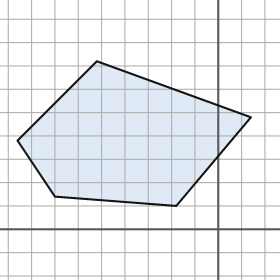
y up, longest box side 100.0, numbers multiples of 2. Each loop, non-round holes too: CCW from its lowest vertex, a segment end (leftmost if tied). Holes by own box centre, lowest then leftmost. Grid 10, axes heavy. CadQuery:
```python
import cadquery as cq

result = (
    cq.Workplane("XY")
    .moveTo(-18.0, 10.0)
    .lineTo(14.0, 48.0)
    .lineTo(-52.0, 72.0)
    .lineTo(-86.0, 38.0)
    .lineTo(-70.0, 14.0)
    .close()
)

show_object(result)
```